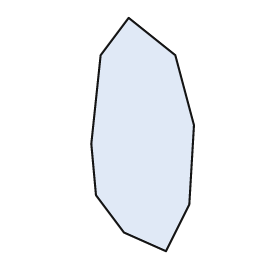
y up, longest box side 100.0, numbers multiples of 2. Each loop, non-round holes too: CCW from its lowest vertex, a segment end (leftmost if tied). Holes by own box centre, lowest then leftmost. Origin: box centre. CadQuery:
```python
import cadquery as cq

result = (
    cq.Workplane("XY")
    .moveTo(10.0, -50.0)
    .lineTo(20.0, -30.0)
    .lineTo(22.0, 4.0)
    .lineTo(14.0, 34.0)
    .lineTo(-6.0, 50.0)
    .lineTo(-18.0, 34.0)
    .lineTo(-22.0, -4.0)
    .lineTo(-20.0, -26.0)
    .lineTo(-8.0, -42.0)
    .close()
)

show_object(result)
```